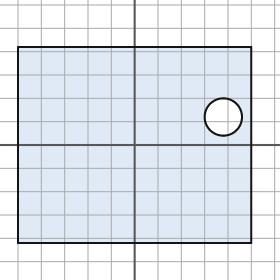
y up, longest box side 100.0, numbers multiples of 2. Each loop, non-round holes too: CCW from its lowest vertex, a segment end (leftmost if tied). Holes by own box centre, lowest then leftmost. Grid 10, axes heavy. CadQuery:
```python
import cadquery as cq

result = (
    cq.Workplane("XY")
    .moveTo(-50.0, -42.0)
    .lineTo(50.0, -42.0)
    .lineTo(50.0, 42.0)
    .lineTo(-50.0, 42.0)
    .close()
    .moveTo(38.0, 12.0)
    .circle(8.0)
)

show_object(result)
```